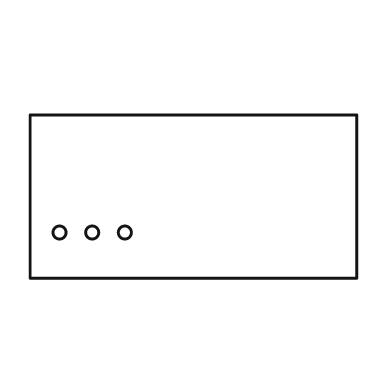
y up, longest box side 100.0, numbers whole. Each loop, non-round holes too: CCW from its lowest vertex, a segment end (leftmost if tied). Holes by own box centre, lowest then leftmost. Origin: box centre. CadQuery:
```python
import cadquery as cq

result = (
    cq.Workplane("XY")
    .moveTo(-50.0, -25.0)
    .lineTo(50.0, -25.0)
    .lineTo(50.0, 25.0)
    .lineTo(-50.0, 25.0)
    .close()
    .moveTo(-41.0, -11.0)
    .circle(2.0)
    .moveTo(-31.0, -11.0)
    .circle(2.0)
    .moveTo(-21.0, -11.0)
    .circle(2.0)
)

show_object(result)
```